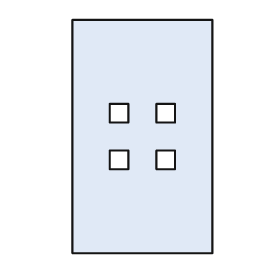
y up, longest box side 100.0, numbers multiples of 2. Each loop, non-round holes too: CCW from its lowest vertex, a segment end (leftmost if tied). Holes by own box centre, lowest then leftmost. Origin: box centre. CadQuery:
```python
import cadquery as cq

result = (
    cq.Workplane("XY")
    .moveTo(-30.0, -50.0)
    .lineTo(30.0, -50.0)
    .lineTo(30.0, 50.0)
    .lineTo(-30.0, 50.0)
    .close()
    .moveTo(-14.0, -14.0)
    .lineTo(-6.0, -14.0)
    .lineTo(-6.0, -6.0)
    .lineTo(-14.0, -6.0)
    .close()
    .moveTo(6.0, -14.0)
    .lineTo(14.0, -14.0)
    .lineTo(14.0, -6.0)
    .lineTo(6.0, -6.0)
    .close()
    .moveTo(-14.0, 6.0)
    .lineTo(-6.0, 6.0)
    .lineTo(-6.0, 14.0)
    .lineTo(-14.0, 14.0)
    .close()
    .moveTo(6.0, 6.0)
    .lineTo(14.0, 6.0)
    .lineTo(14.0, 14.0)
    .lineTo(6.0, 14.0)
    .close()
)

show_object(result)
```